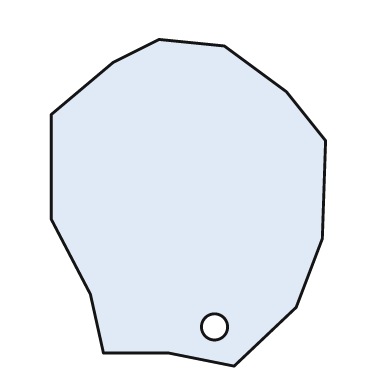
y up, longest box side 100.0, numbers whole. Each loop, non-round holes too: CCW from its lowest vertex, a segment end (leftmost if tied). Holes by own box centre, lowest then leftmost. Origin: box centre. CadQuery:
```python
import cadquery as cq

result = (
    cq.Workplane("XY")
    .moveTo(14.0, -50.0)
    .lineTo(33.0, -32.0)
    .lineTo(41.0, -11.0)
    .lineTo(42.0, 19.0)
    .lineTo(30.0, 34.0)
    .lineTo(11.0, 48.0)
    .lineTo(-9.0, 50.0)
    .lineTo(-23.0, 43.0)
    .lineTo(-42.0, 27.0)
    .lineTo(-42.0, -5.0)
    .lineTo(-30.0, -28.0)
    .lineTo(-26.0, -46.0)
    .lineTo(-6.0, -46.0)
    .close()
    .moveTo(8.0, -38.0)
    .circle(4.0)
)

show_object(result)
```